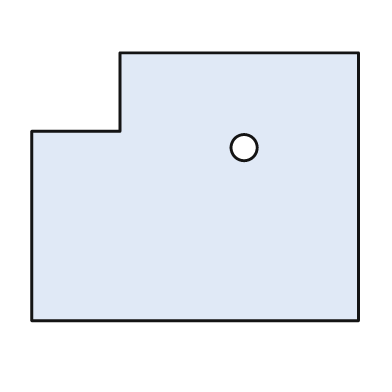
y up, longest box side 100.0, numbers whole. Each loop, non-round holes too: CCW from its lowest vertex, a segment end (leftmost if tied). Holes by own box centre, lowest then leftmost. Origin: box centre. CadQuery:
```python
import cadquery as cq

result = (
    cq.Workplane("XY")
    .moveTo(-50.0, -41.0)
    .lineTo(50.0, -41.0)
    .lineTo(50.0, 41.0)
    .lineTo(-23.0, 41.0)
    .lineTo(-23.0, 17.0)
    .lineTo(-50.0, 17.0)
    .close()
    .moveTo(15.0, 12.0)
    .circle(4.0)
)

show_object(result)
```